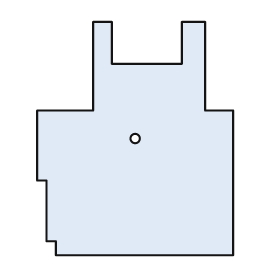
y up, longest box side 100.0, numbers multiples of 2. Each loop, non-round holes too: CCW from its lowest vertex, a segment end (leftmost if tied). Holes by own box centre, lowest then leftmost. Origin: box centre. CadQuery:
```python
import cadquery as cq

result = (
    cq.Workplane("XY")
    .moveTo(-34.0, -50.0)
    .lineTo(42.0, -50.0)
    .lineTo(42.0, 12.0)
    .lineTo(30.0, 12.0)
    .lineTo(30.0, 50.0)
    .lineTo(20.0, 50.0)
    .lineTo(20.0, 32.0)
    .lineTo(-10.0, 32.0)
    .lineTo(-10.0, 50.0)
    .lineTo(-18.0, 50.0)
    .lineTo(-18.0, 12.0)
    .lineTo(-42.0, 12.0)
    .lineTo(-42.0, -18.0)
    .lineTo(-38.0, -18.0)
    .lineTo(-38.0, -44.0)
    .lineTo(-34.0, -44.0)
    .close()
    .moveTo(0.0, 0.0)
    .circle(2.0)
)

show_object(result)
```